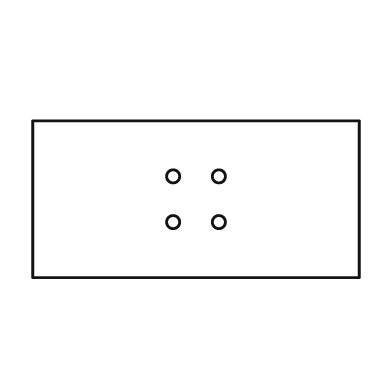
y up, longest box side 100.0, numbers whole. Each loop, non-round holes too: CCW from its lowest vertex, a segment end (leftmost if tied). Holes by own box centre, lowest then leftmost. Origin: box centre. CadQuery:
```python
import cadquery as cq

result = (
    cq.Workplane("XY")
    .moveTo(-50.0, -24.0)
    .lineTo(50.0, -24.0)
    .lineTo(50.0, 24.0)
    .lineTo(-50.0, 24.0)
    .close()
    .moveTo(-7.0, -7.0)
    .circle(2.0)
    .moveTo(7.0, -7.0)
    .circle(2.0)
    .moveTo(-7.0, 7.0)
    .circle(2.0)
    .moveTo(7.0, 7.0)
    .circle(2.0)
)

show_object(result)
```